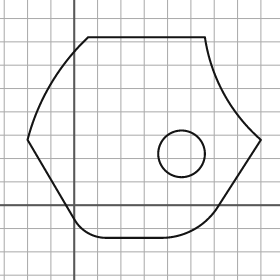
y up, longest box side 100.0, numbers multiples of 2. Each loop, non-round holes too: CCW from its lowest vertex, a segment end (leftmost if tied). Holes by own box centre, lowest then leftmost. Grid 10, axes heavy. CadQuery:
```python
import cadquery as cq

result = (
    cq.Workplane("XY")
    .moveTo(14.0, -14.0)
    .lineTo(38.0, -14.0)
    .threePointArc((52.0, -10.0), (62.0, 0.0))
    .lineTo(80.0, 28.0)
    .threePointArc((64.0, 48.0), (56.0, 72.0))
    .lineTo(6.0, 72.0)
    .threePointArc((-10.0, 52.0), (-20.0, 28.0))
    .lineTo(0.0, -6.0)
    .threePointArc((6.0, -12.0), (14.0, -14.0))
    .close()
    .moveTo(46.0, 22.0)
    .circle(10.0)
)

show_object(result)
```